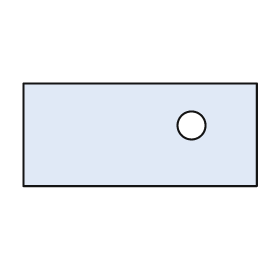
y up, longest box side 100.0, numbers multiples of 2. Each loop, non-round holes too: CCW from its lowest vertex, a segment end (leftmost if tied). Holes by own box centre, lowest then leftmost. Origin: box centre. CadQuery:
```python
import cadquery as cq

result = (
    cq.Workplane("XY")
    .moveTo(-50.0, -22.0)
    .lineTo(50.0, -22.0)
    .lineTo(50.0, 22.0)
    .lineTo(-50.0, 22.0)
    .close()
    .moveTo(22.0, 4.0)
    .circle(6.0)
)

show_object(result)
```